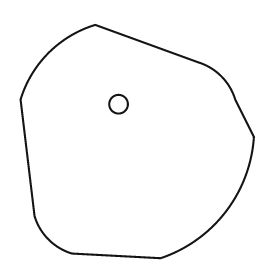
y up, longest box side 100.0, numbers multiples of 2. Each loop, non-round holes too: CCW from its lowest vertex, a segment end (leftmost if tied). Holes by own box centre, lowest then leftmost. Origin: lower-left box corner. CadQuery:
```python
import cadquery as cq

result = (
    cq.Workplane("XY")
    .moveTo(60.0, 0.0)
    .threePointArc((88.0, 20.0), (100.0, 52.0))
    .lineTo(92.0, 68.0)
    .threePointArc((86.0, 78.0), (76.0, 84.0))
    .lineTo(32.0, 100.0)
    .threePointArc((12.0, 88.0), (0.0, 68.0))
    .lineTo(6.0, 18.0)
    .threePointArc((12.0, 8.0), (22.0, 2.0))
    .close()
    .moveTo(42.0, 66.0)
    .circle(4.0)
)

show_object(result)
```